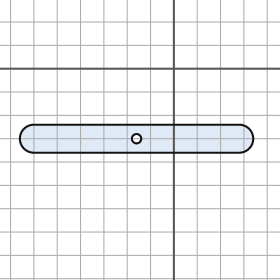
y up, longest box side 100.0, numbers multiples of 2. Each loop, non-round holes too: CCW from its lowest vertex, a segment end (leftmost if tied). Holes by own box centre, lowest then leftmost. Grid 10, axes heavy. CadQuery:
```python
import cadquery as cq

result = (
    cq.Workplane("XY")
    .moveTo(-60.0, -36.0)
    .lineTo(28.0, -36.0)
    .threePointArc((34.0, -30.0), (28.0, -24.0))
    .lineTo(-60.0, -24.0)
    .threePointArc((-66.0, -30.0), (-60.0, -36.0))
    .close()
    .moveTo(-16.0, -30.0)
    .circle(2.0)
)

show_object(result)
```